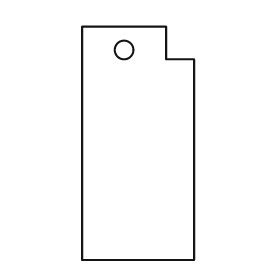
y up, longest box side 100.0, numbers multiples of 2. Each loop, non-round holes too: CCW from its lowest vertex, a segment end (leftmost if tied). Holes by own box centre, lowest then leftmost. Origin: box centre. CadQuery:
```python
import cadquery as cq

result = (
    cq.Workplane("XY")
    .moveTo(-24.0, -50.0)
    .lineTo(24.0, -50.0)
    .lineTo(24.0, 36.0)
    .lineTo(12.0, 36.0)
    .lineTo(12.0, 50.0)
    .lineTo(-24.0, 50.0)
    .close()
    .moveTo(-6.0, 40.0)
    .circle(4.0)
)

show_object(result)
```